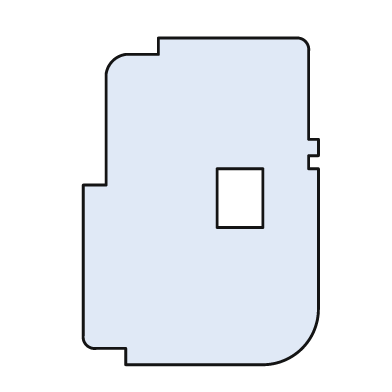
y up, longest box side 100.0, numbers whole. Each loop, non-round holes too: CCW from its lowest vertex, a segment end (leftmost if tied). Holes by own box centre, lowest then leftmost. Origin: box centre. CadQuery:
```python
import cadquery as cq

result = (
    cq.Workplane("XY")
    .moveTo(-23.0, -50.0)
    .lineTo(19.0, -50.0)
    .threePointArc((31.0, -45.0), (36.0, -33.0))
    .lineTo(36.0, 10.0)
    .lineTo(33.0, 10.0)
    .lineTo(33.0, 14.0)
    .lineTo(36.0, 14.0)
    .lineTo(36.0, 19.0)
    .lineTo(33.0, 19.0)
    .lineTo(33.0, 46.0)
    .threePointArc((32.0, 49.0), (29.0, 50.0))
    .lineTo(-13.0, 50.0)
    .lineTo(-13.0, 45.0)
    .lineTo(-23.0, 45.0)
    .threePointArc((-27.0, 43.0), (-29.0, 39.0))
    .lineTo(-29.0, 5.0)
    .lineTo(-36.0, 5.0)
    .lineTo(-36.0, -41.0)
    .threePointArc((-35.0, -44.0), (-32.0, -45.0))
    .lineTo(-23.0, -45.0)
    .close()
    .moveTo(5.0, -8.0)
    .lineTo(19.0, -8.0)
    .lineTo(19.0, 10.0)
    .lineTo(5.0, 10.0)
    .close()
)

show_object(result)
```